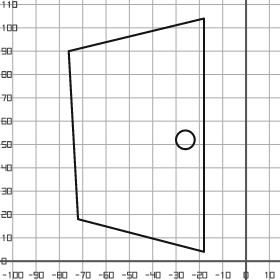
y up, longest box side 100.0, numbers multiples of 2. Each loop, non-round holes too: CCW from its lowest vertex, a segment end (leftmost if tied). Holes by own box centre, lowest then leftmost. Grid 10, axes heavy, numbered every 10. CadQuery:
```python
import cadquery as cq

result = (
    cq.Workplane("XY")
    .moveTo(-18.0, 4.0)
    .lineTo(-18.0, 104.0)
    .lineTo(-76.0, 90.0)
    .lineTo(-72.0, 18.0)
    .close()
    .moveTo(-26.0, 52.0)
    .circle(4.0)
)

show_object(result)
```